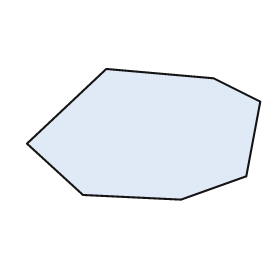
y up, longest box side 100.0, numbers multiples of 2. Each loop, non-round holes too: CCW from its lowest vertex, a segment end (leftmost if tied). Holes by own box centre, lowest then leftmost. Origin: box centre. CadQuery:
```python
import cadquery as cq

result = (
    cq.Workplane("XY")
    .moveTo(16.0, -28.0)
    .lineTo(44.0, -18.0)
    .lineTo(50.0, 14.0)
    .lineTo(30.0, 24.0)
    .lineTo(-16.0, 28.0)
    .lineTo(-50.0, -4.0)
    .lineTo(-26.0, -26.0)
    .close()
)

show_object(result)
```